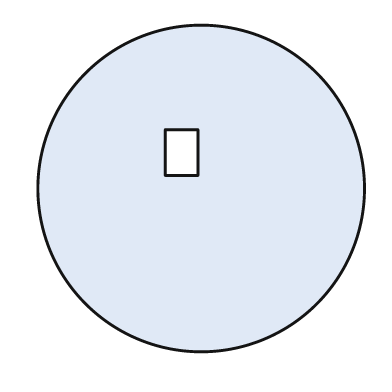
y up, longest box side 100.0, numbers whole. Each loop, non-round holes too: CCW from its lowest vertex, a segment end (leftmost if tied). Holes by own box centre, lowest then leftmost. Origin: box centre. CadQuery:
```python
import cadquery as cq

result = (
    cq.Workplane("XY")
    .moveTo(0.0, 0.0)
    .circle(50.0)
    .moveTo(-11.0, 4.0)
    .lineTo(-1.0, 4.0)
    .lineTo(-1.0, 18.0)
    .lineTo(-11.0, 18.0)
    .close()
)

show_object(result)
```